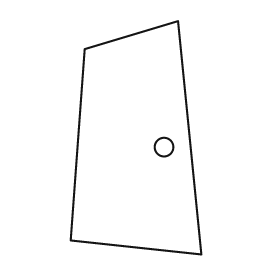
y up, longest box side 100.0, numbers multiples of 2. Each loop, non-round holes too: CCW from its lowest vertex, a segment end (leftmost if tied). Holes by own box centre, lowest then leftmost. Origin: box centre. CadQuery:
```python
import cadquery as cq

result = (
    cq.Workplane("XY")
    .moveTo(28.0, -50.0)
    .lineTo(18.0, 50.0)
    .lineTo(-22.0, 38.0)
    .lineTo(-28.0, -44.0)
    .close()
    .moveTo(12.0, -4.0)
    .circle(4.0)
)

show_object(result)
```